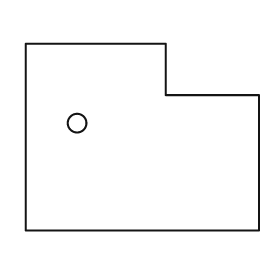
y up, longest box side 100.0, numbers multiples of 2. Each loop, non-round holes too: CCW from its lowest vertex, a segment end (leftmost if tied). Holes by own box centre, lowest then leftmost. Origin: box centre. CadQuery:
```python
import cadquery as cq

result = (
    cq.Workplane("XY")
    .moveTo(-50.0, -40.0)
    .lineTo(50.0, -40.0)
    .lineTo(50.0, 18.0)
    .lineTo(10.0, 18.0)
    .lineTo(10.0, 40.0)
    .lineTo(-50.0, 40.0)
    .close()
    .moveTo(-28.0, 6.0)
    .circle(4.0)
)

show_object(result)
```